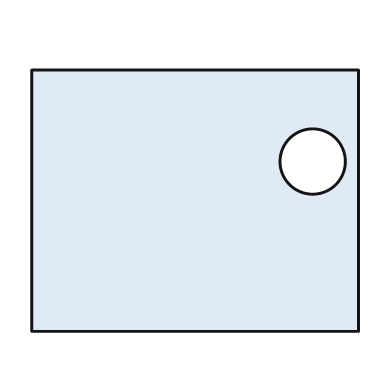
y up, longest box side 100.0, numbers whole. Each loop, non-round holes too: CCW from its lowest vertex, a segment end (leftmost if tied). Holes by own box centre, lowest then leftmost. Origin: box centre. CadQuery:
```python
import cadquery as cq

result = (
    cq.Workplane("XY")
    .moveTo(-50.0, -40.0)
    .lineTo(50.0, -40.0)
    .lineTo(50.0, 40.0)
    .lineTo(-50.0, 40.0)
    .close()
    .moveTo(36.0, 12.0)
    .circle(10.0)
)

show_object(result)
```